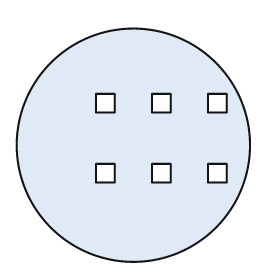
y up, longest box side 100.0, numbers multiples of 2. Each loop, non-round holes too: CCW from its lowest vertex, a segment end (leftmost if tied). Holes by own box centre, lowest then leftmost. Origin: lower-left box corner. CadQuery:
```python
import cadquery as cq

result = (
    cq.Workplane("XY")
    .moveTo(50.0, 50.0)
    .circle(50.0)
    .moveTo(34.0, 34.0)
    .lineTo(42.0, 34.0)
    .lineTo(42.0, 42.0)
    .lineTo(34.0, 42.0)
    .close()
    .moveTo(58.0, 34.0)
    .lineTo(66.0, 34.0)
    .lineTo(66.0, 42.0)
    .lineTo(58.0, 42.0)
    .close()
    .moveTo(82.0, 34.0)
    .lineTo(90.0, 34.0)
    .lineTo(90.0, 42.0)
    .lineTo(82.0, 42.0)
    .close()
    .moveTo(34.0, 64.0)
    .lineTo(42.0, 64.0)
    .lineTo(42.0, 72.0)
    .lineTo(34.0, 72.0)
    .close()
    .moveTo(58.0, 64.0)
    .lineTo(66.0, 64.0)
    .lineTo(66.0, 72.0)
    .lineTo(58.0, 72.0)
    .close()
    .moveTo(82.0, 64.0)
    .lineTo(90.0, 64.0)
    .lineTo(90.0, 72.0)
    .lineTo(82.0, 72.0)
    .close()
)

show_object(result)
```